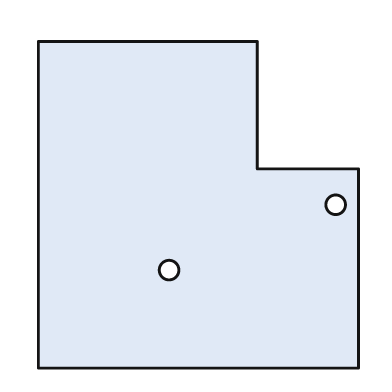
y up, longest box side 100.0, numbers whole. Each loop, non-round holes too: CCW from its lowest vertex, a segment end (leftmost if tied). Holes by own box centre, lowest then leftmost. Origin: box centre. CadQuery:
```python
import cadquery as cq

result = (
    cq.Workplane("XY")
    .moveTo(-49.0, -50.0)
    .lineTo(49.0, -50.0)
    .lineTo(49.0, 11.0)
    .lineTo(18.0, 11.0)
    .lineTo(18.0, 50.0)
    .lineTo(-49.0, 50.0)
    .close()
    .moveTo(-9.0, -20.0)
    .circle(3.0)
    .moveTo(42.0, 0.0)
    .circle(3.0)
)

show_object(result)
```